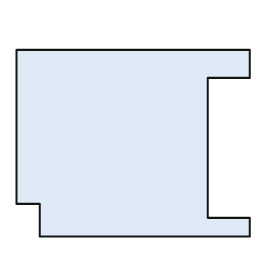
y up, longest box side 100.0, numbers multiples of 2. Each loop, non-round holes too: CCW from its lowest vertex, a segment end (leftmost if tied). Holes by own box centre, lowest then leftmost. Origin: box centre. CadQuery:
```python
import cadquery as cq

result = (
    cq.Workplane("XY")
    .moveTo(-40.0, -40.0)
    .lineTo(50.0, -40.0)
    .lineTo(50.0, -32.0)
    .lineTo(32.0, -32.0)
    .lineTo(32.0, 28.0)
    .lineTo(50.0, 28.0)
    .lineTo(50.0, 40.0)
    .lineTo(-50.0, 40.0)
    .lineTo(-50.0, -26.0)
    .lineTo(-40.0, -26.0)
    .close()
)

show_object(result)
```